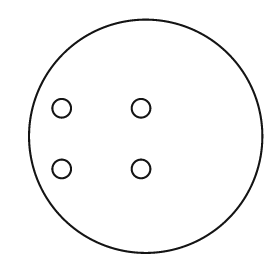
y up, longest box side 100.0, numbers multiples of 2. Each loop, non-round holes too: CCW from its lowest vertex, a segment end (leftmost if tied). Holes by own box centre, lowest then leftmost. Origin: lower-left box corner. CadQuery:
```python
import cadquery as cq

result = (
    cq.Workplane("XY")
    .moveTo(50.0, 50.0)
    .circle(50.0)
    .moveTo(14.0, 36.0)
    .circle(4.0)
    .moveTo(48.0, 36.0)
    .circle(4.0)
    .moveTo(14.0, 62.0)
    .circle(4.0)
    .moveTo(48.0, 62.0)
    .circle(4.0)
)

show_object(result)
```